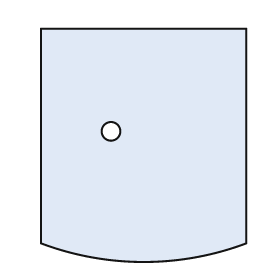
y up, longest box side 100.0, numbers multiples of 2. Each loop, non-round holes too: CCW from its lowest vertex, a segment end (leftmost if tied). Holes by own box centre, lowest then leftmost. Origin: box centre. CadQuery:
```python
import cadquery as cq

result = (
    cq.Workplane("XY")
    .moveTo(-44.0, -42.0)
    .threePointArc((0.0, -50.0), (44.0, -42.0))
    .lineTo(44.0, 50.0)
    .lineTo(-44.0, 50.0)
    .close()
    .moveTo(-14.0, 6.0)
    .circle(4.0)
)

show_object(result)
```